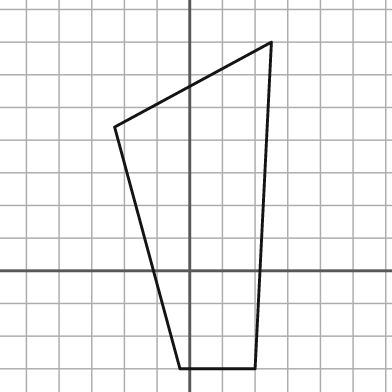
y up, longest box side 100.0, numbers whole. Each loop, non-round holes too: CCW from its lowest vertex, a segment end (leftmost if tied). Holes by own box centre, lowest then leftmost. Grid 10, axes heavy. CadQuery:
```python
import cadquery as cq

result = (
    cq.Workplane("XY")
    .moveTo(-3.0, -30.0)
    .lineTo(20.0, -30.0)
    .lineTo(25.0, 70.0)
    .lineTo(-23.0, 44.0)
    .close()
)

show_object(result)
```